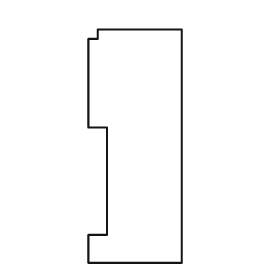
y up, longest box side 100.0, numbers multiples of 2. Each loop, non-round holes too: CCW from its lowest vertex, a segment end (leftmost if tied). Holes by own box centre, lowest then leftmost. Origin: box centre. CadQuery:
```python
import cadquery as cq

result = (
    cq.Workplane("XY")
    .moveTo(-20.0, -50.0)
    .lineTo(20.0, -50.0)
    .lineTo(20.0, 50.0)
    .lineTo(-16.0, 50.0)
    .lineTo(-16.0, 46.0)
    .lineTo(-20.0, 46.0)
    .lineTo(-20.0, 8.0)
    .lineTo(-12.0, 8.0)
    .lineTo(-12.0, -38.0)
    .lineTo(-20.0, -38.0)
    .close()
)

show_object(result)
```